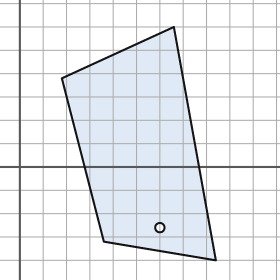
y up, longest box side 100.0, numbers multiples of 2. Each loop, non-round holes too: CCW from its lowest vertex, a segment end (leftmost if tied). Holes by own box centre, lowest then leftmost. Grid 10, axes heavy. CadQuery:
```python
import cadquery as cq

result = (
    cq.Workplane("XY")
    .moveTo(84.0, -40.0)
    .lineTo(66.0, 60.0)
    .lineTo(18.0, 38.0)
    .lineTo(36.0, -32.0)
    .close()
    .moveTo(60.0, -26.0)
    .circle(2.0)
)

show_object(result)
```